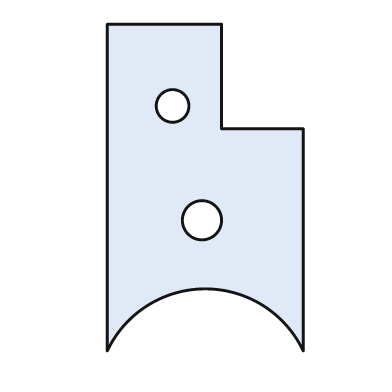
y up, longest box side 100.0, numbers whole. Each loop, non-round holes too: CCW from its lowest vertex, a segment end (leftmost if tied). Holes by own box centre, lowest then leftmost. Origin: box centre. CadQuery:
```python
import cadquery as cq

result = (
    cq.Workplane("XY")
    .moveTo(-30.0, -50.0)
    .threePointArc((0.0, -31.0), (30.0, -50.0))
    .lineTo(30.0, 18.0)
    .lineTo(5.0, 18.0)
    .lineTo(5.0, 50.0)
    .lineTo(-30.0, 50.0)
    .close()
    .moveTo(-1.0, -10.0)
    .circle(6.0)
    .moveTo(-10.0, 25.0)
    .circle(5.0)
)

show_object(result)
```